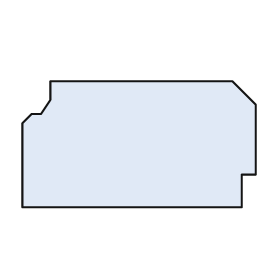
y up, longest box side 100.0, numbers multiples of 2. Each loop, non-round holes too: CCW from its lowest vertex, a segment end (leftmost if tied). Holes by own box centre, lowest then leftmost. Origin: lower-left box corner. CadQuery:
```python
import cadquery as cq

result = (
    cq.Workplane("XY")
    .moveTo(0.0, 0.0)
    .lineTo(94.0, 0.0)
    .lineTo(94.0, 14.0)
    .lineTo(100.0, 14.0)
    .lineTo(100.0, 44.0)
    .lineTo(90.0, 54.0)
    .lineTo(12.0, 54.0)
    .lineTo(12.0, 46.0)
    .lineTo(8.0, 40.0)
    .lineTo(4.0, 40.0)
    .lineTo(0.0, 36.0)
    .close()
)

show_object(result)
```